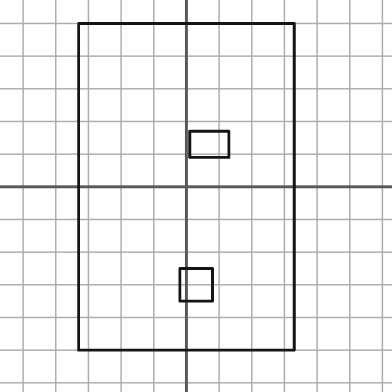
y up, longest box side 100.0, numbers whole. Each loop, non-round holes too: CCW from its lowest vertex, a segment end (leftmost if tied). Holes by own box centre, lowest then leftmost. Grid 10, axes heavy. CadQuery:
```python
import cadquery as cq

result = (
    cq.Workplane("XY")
    .moveTo(-33.0, -50.0)
    .lineTo(33.0, -50.0)
    .lineTo(33.0, 50.0)
    .lineTo(-33.0, 50.0)
    .close()
    .moveTo(-2.0, -35.0)
    .lineTo(8.0, -35.0)
    .lineTo(8.0, -25.0)
    .lineTo(-2.0, -25.0)
    .close()
    .moveTo(1.0, 9.0)
    .lineTo(13.0, 9.0)
    .lineTo(13.0, 17.0)
    .lineTo(1.0, 17.0)
    .close()
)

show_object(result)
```